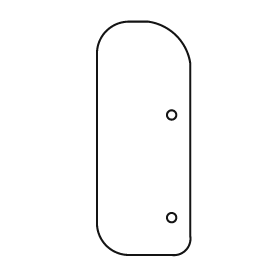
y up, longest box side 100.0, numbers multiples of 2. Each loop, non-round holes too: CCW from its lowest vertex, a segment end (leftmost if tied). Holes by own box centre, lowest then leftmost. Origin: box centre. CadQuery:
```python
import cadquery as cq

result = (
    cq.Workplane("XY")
    .moveTo(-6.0, -50.0)
    .lineTo(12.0, -50.0)
    .threePointArc((18.0, -48.0), (20.0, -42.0))
    .lineTo(20.0, 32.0)
    .threePointArc((14.0, 44.0), (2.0, 50.0))
    .lineTo(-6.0, 50.0)
    .threePointArc((-16.0, 46.0), (-20.0, 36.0))
    .lineTo(-20.0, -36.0)
    .threePointArc((-16.0, -46.0), (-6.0, -50.0))
    .close()
    .moveTo(12.0, -34.0)
    .circle(2.0)
    .moveTo(12.0, 10.0)
    .circle(2.0)
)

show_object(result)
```